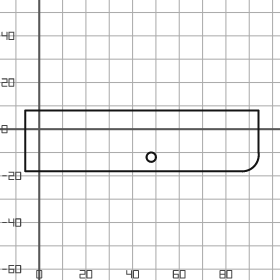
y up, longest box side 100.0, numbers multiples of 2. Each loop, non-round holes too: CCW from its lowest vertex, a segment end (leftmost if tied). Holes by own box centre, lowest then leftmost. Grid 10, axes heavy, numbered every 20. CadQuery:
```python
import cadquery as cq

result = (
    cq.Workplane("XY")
    .moveTo(-6.0, -18.0)
    .lineTo(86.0, -18.0)
    .threePointArc((92.0, -16.0), (94.0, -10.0))
    .lineTo(94.0, 8.0)
    .lineTo(-6.0, 8.0)
    .close()
    .moveTo(48.0, -12.0)
    .circle(2.0)
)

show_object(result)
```